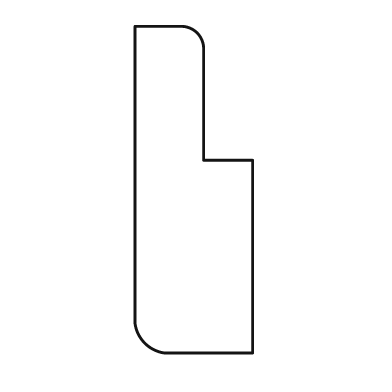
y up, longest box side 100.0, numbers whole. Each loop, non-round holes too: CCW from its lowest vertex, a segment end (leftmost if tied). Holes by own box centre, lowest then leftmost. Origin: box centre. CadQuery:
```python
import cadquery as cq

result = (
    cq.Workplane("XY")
    .moveTo(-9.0, -50.0)
    .lineTo(18.0, -50.0)
    .lineTo(18.0, 9.0)
    .lineTo(3.0, 9.0)
    .lineTo(3.0, 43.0)
    .threePointArc((1.0, 48.0), (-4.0, 50.0))
    .lineTo(-18.0, 50.0)
    .lineTo(-18.0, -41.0)
    .threePointArc((-15.0, -47.0), (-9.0, -50.0))
    .close()
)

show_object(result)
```